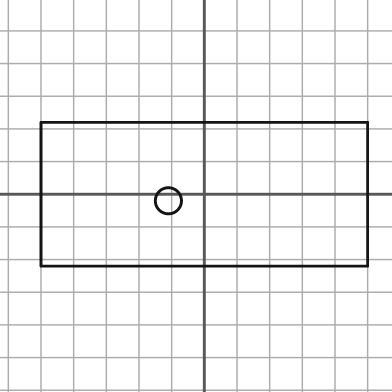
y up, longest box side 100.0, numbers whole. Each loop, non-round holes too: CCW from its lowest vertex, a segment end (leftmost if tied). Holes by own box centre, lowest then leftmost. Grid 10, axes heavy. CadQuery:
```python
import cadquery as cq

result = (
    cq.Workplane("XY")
    .moveTo(-50.0, -22.0)
    .lineTo(50.0, -22.0)
    .lineTo(50.0, 22.0)
    .lineTo(-50.0, 22.0)
    .close()
    .moveTo(-11.0, -2.0)
    .circle(4.0)
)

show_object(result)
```